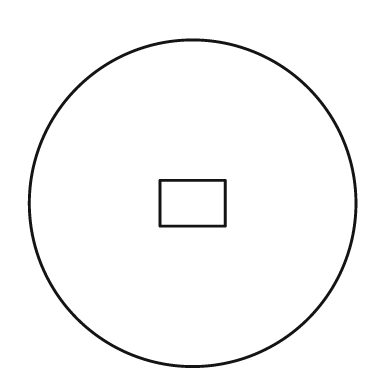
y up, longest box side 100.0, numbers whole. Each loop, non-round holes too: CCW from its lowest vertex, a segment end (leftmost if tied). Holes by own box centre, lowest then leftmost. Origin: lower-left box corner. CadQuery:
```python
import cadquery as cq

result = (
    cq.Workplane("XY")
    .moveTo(50.0, 50.0)
    .circle(50.0)
    .moveTo(40.0, 43.0)
    .lineTo(60.0, 43.0)
    .lineTo(60.0, 57.0)
    .lineTo(40.0, 57.0)
    .close()
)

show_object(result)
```